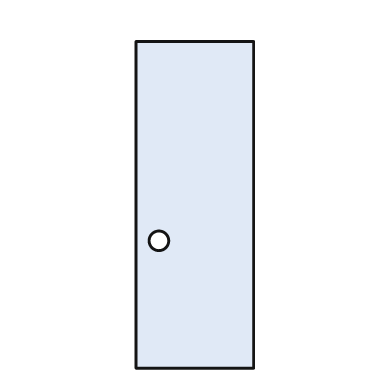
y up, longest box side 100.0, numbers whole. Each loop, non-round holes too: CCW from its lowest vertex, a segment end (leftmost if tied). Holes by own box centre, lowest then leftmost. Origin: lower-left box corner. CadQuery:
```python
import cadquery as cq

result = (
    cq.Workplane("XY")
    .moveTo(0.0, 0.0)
    .lineTo(36.0, 0.0)
    .lineTo(36.0, 100.0)
    .lineTo(0.0, 100.0)
    .close()
    .moveTo(7.0, 39.0)
    .circle(3.0)
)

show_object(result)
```